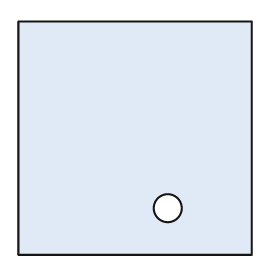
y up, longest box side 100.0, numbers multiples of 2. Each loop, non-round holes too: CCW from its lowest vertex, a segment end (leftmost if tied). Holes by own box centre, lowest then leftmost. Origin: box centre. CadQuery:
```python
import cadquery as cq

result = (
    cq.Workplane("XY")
    .moveTo(-50.0, -50.0)
    .lineTo(50.0, -50.0)
    .lineTo(50.0, 50.0)
    .lineTo(-50.0, 50.0)
    .close()
    .moveTo(14.0, -30.0)
    .circle(6.0)
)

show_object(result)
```